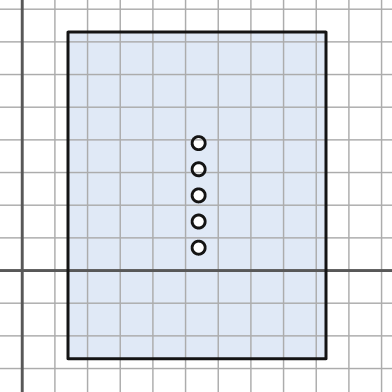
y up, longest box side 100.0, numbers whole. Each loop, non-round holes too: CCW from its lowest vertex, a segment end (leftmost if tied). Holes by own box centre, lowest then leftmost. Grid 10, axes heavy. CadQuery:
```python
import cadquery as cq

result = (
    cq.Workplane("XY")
    .moveTo(14.0, -27.0)
    .lineTo(93.0, -27.0)
    .lineTo(93.0, 73.0)
    .lineTo(14.0, 73.0)
    .close()
    .moveTo(54.0, 7.0)
    .circle(2.0)
    .moveTo(54.0, 15.0)
    .circle(2.0)
    .moveTo(54.0, 23.0)
    .circle(2.0)
    .moveTo(54.0, 31.0)
    .circle(2.0)
    .moveTo(54.0, 39.0)
    .circle(2.0)
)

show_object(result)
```